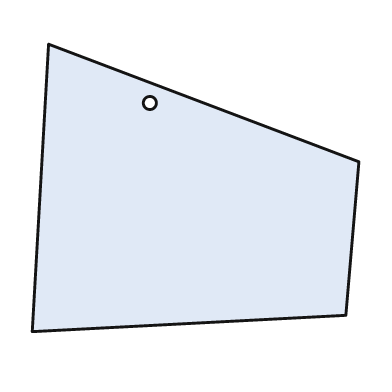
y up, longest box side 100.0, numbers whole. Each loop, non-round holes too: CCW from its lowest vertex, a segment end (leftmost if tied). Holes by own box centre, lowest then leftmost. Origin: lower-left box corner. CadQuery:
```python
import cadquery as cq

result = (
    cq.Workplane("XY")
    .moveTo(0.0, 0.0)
    .lineTo(96.0, 5.0)
    .lineTo(100.0, 52.0)
    .lineTo(5.0, 88.0)
    .close()
    .moveTo(36.0, 70.0)
    .circle(2.0)
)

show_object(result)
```